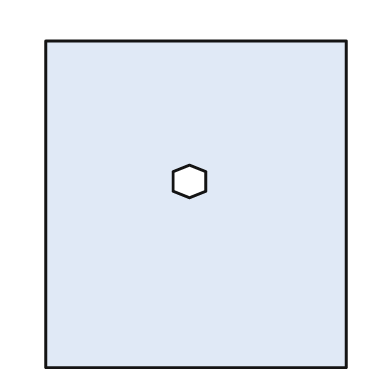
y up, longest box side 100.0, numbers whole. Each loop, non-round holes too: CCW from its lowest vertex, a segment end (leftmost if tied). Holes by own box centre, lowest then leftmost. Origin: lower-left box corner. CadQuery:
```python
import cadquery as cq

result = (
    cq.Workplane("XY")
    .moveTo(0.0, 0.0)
    .lineTo(92.0, 0.0)
    .lineTo(92.0, 100.0)
    .lineTo(0.0, 100.0)
    .close()
    .moveTo(44.0, 52.0)
    .lineTo(49.0, 54.0)
    .lineTo(49.0, 60.0)
    .lineTo(44.0, 62.0)
    .lineTo(39.0, 60.0)
    .lineTo(39.0, 54.0)
    .close()
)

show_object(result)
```